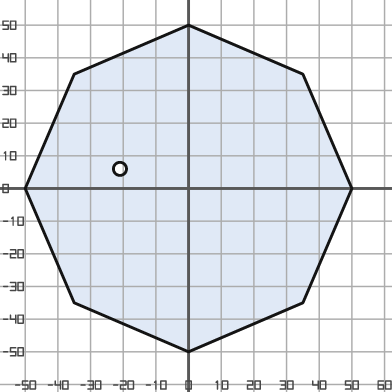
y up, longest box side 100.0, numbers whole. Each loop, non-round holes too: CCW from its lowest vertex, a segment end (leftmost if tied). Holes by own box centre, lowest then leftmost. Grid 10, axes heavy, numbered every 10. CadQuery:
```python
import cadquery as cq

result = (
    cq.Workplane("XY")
    .moveTo(0.0, -50.0)
    .lineTo(35.0, -35.0)
    .lineTo(50.0, 0.0)
    .lineTo(35.0, 35.0)
    .lineTo(0.0, 50.0)
    .lineTo(-35.0, 35.0)
    .lineTo(-50.0, 0.0)
    .lineTo(-35.0, -35.0)
    .close()
    .moveTo(-21.0, 6.0)
    .circle(2.0)
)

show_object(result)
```